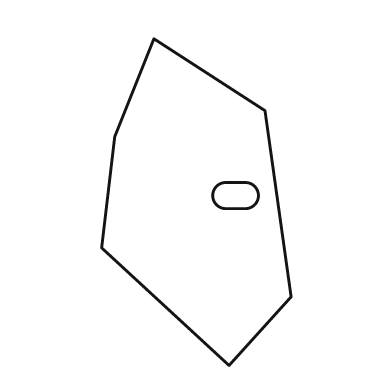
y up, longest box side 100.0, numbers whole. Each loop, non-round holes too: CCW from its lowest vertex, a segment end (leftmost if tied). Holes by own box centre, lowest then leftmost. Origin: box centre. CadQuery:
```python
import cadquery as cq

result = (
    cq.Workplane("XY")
    .moveTo(10.0, -50.0)
    .lineTo(29.0, -29.0)
    .lineTo(21.0, 28.0)
    .lineTo(-13.0, 50.0)
    .lineTo(-25.0, 20.0)
    .lineTo(-29.0, -14.0)
    .close()
    .moveTo(9.0, -2.0)
    .lineTo(15.0, -2.0)
    .threePointArc((19.0, 2.0), (15.0, 6.0))
    .lineTo(9.0, 6.0)
    .threePointArc((5.0, 2.0), (9.0, -2.0))
    .close()
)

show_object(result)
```